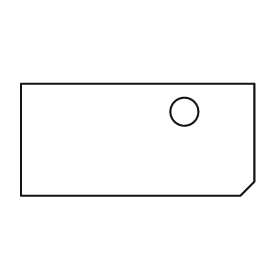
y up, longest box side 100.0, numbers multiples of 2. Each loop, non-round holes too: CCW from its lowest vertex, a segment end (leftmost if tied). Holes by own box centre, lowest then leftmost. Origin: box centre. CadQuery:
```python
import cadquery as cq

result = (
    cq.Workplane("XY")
    .moveTo(-50.0, -24.0)
    .lineTo(44.0, -24.0)
    .lineTo(50.0, -18.0)
    .lineTo(50.0, 24.0)
    .lineTo(-50.0, 24.0)
    .close()
    .moveTo(20.0, 12.0)
    .circle(6.0)
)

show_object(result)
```